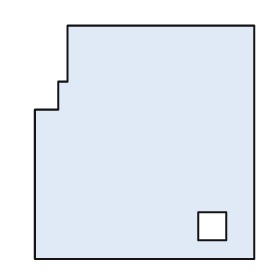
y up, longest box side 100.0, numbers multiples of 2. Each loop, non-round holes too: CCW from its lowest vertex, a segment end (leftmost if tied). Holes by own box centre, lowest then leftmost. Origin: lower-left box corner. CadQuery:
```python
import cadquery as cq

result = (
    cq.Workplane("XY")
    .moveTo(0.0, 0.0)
    .lineTo(94.0, 0.0)
    .lineTo(94.0, 100.0)
    .lineTo(14.0, 100.0)
    .lineTo(14.0, 76.0)
    .lineTo(10.0, 76.0)
    .lineTo(10.0, 64.0)
    .lineTo(0.0, 64.0)
    .close()
    .moveTo(70.0, 8.0)
    .lineTo(82.0, 8.0)
    .lineTo(82.0, 20.0)
    .lineTo(70.0, 20.0)
    .close()
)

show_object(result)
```